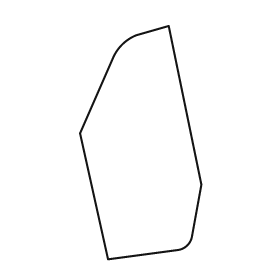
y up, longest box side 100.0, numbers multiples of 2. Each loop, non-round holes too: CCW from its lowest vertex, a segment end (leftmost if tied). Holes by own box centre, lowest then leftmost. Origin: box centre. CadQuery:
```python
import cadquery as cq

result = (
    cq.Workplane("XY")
    .moveTo(-14.0, -50.0)
    .lineTo(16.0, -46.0)
    .threePointArc((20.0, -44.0), (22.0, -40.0))
    .lineTo(26.0, -18.0)
    .lineTo(12.0, 50.0)
    .lineTo(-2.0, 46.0)
    .threePointArc((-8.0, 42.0), (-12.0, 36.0))
    .lineTo(-26.0, 4.0)
    .close()
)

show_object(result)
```